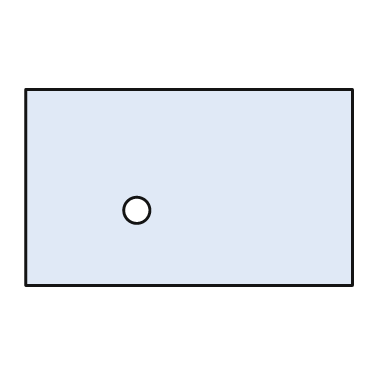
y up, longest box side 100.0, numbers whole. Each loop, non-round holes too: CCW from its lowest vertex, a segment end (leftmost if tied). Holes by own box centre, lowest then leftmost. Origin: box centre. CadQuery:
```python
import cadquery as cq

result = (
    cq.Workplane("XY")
    .moveTo(-50.0, -30.0)
    .lineTo(50.0, -30.0)
    .lineTo(50.0, 30.0)
    .lineTo(-50.0, 30.0)
    .close()
    .moveTo(-16.0, -7.0)
    .circle(4.0)
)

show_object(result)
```